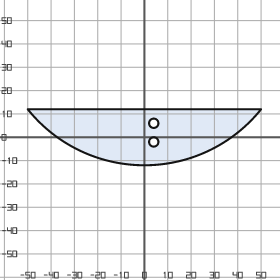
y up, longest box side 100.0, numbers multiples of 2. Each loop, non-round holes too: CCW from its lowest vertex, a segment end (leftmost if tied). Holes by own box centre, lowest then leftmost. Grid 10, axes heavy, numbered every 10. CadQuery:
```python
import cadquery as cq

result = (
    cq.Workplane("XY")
    .moveTo(-50.0, 12.0)
    .threePointArc((0.0, -12.0), (50.0, 12.0))
    .close()
    .moveTo(4.0, -2.0)
    .circle(2.0)
    .moveTo(4.0, 6.0)
    .circle(2.0)
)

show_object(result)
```